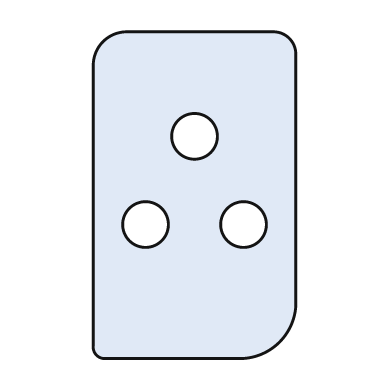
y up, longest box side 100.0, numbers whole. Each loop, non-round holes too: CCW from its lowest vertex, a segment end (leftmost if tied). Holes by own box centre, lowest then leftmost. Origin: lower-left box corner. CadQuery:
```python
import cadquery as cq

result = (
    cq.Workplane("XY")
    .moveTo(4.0, 0.0)
    .lineTo(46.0, 0.0)
    .threePointArc((57.0, 5.0), (62.0, 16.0))
    .lineTo(62.0, 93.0)
    .threePointArc((60.0, 98.0), (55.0, 100.0))
    .lineTo(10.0, 100.0)
    .threePointArc((3.0, 97.0), (0.0, 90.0))
    .lineTo(0.0, 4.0)
    .threePointArc((1.0, 1.0), (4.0, 0.0))
    .close()
    .moveTo(16.0, 41.0)
    .circle(7.0)
    .moveTo(46.0, 41.0)
    .circle(7.0)
    .moveTo(31.0, 68.0)
    .circle(7.0)
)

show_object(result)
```